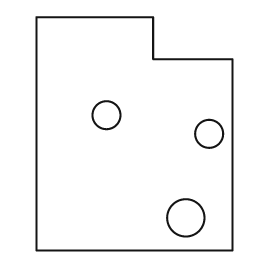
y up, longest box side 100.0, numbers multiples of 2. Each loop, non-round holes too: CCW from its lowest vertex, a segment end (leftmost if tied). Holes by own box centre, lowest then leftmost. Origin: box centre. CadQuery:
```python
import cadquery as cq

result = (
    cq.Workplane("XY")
    .moveTo(-42.0, -50.0)
    .lineTo(42.0, -50.0)
    .lineTo(42.0, 32.0)
    .lineTo(8.0, 32.0)
    .lineTo(8.0, 50.0)
    .lineTo(-42.0, 50.0)
    .close()
    .moveTo(22.0, -36.0)
    .circle(8.0)
    .moveTo(32.0, 0.0)
    .circle(6.0)
    .moveTo(-12.0, 8.0)
    .circle(6.0)
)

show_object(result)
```